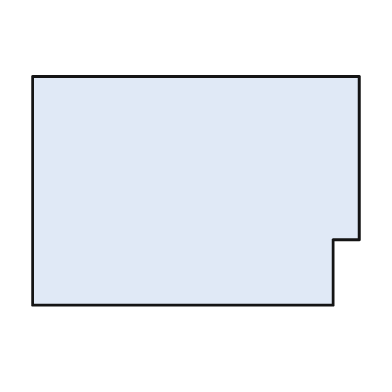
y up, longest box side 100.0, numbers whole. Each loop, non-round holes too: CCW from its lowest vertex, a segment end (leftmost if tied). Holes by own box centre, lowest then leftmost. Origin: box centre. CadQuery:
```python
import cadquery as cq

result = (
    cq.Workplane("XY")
    .moveTo(-50.0, -35.0)
    .lineTo(42.0, -35.0)
    .lineTo(42.0, -15.0)
    .lineTo(50.0, -15.0)
    .lineTo(50.0, 35.0)
    .lineTo(-50.0, 35.0)
    .close()
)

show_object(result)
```